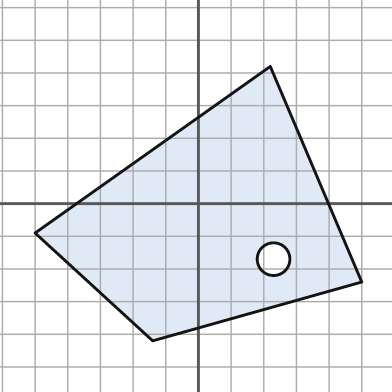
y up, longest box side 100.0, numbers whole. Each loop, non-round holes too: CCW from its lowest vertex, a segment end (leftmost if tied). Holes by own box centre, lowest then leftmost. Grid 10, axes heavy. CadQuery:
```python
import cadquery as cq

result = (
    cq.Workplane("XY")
    .moveTo(-14.0, -42.0)
    .lineTo(50.0, -24.0)
    .lineTo(22.0, 42.0)
    .lineTo(-50.0, -9.0)
    .close()
    .moveTo(23.0, -17.0)
    .circle(5.0)
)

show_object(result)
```